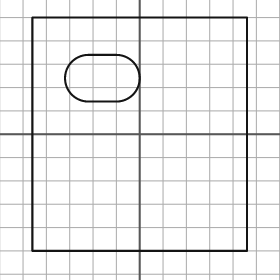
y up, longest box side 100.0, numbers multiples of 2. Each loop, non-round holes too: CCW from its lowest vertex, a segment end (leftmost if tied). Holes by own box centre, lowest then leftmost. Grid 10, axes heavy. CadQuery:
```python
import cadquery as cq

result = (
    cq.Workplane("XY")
    .moveTo(-46.0, -50.0)
    .lineTo(46.0, -50.0)
    .lineTo(46.0, 50.0)
    .lineTo(-46.0, 50.0)
    .close()
    .moveTo(-22.0, 14.0)
    .lineTo(-10.0, 14.0)
    .threePointArc((0.0, 24.0), (-10.0, 34.0))
    .lineTo(-22.0, 34.0)
    .threePointArc((-32.0, 24.0), (-22.0, 14.0))
    .close()
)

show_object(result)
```